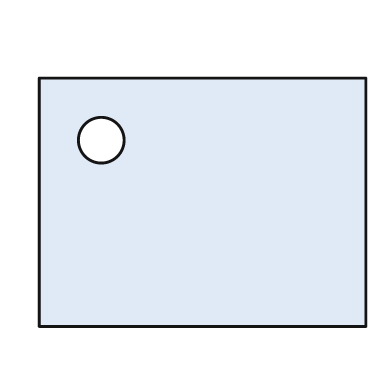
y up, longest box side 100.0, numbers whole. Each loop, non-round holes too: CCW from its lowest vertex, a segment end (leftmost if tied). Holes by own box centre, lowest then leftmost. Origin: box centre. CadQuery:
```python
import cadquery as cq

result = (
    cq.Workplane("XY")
    .moveTo(-50.0, -38.0)
    .lineTo(50.0, -38.0)
    .lineTo(50.0, 38.0)
    .lineTo(-50.0, 38.0)
    .close()
    .moveTo(-31.0, 19.0)
    .circle(7.0)
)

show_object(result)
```